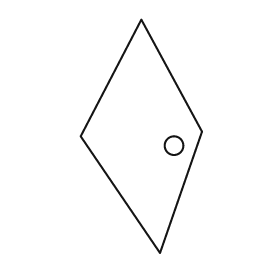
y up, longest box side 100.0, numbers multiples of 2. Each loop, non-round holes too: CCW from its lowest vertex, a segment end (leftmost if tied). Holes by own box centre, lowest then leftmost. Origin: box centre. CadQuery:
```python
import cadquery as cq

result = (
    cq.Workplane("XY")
    .moveTo(8.0, -50.0)
    .lineTo(26.0, 2.0)
    .lineTo(0.0, 50.0)
    .lineTo(-26.0, 0.0)
    .close()
    .moveTo(14.0, -4.0)
    .circle(4.0)
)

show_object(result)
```